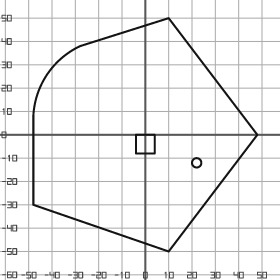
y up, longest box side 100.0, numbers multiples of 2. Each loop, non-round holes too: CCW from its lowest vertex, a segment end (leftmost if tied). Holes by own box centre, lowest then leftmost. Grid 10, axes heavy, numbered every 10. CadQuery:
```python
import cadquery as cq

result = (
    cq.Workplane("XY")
    .moveTo(10.0, -50.0)
    .lineTo(48.0, 0.0)
    .lineTo(10.0, 50.0)
    .lineTo(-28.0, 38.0)
    .threePointArc((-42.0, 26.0), (-48.0, 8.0))
    .lineTo(-48.0, -30.0)
    .close()
    .moveTo(22.0, -12.0)
    .circle(2.0)
    .moveTo(-4.0, -8.0)
    .lineTo(4.0, -8.0)
    .lineTo(4.0, 0.0)
    .lineTo(-4.0, 0.0)
    .close()
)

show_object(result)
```